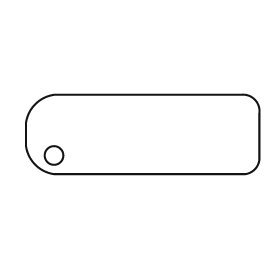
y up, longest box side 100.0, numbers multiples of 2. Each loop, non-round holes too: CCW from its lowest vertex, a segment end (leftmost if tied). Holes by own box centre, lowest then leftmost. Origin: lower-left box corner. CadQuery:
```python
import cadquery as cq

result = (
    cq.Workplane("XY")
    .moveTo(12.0, 0.0)
    .lineTo(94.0, 0.0)
    .threePointArc((98.0, 2.0), (100.0, 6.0))
    .lineTo(100.0, 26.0)
    .threePointArc((98.0, 32.0), (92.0, 34.0))
    .lineTo(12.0, 34.0)
    .threePointArc((4.0, 30.0), (0.0, 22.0))
    .lineTo(0.0, 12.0)
    .threePointArc((4.0, 4.0), (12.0, 0.0))
    .close()
    .moveTo(12.0, 8.0)
    .circle(4.0)
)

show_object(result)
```